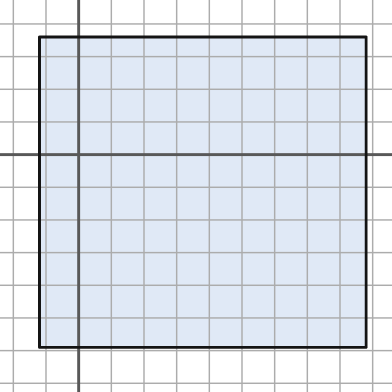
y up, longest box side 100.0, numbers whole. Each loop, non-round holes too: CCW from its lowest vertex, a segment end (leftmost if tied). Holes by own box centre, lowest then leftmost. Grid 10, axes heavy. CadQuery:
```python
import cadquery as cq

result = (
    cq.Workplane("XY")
    .moveTo(-12.0, -59.0)
    .lineTo(88.0, -59.0)
    .lineTo(88.0, 36.0)
    .lineTo(-12.0, 36.0)
    .close()
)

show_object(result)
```